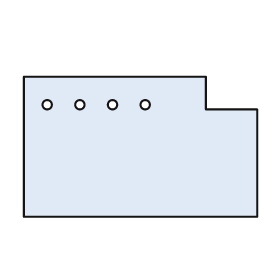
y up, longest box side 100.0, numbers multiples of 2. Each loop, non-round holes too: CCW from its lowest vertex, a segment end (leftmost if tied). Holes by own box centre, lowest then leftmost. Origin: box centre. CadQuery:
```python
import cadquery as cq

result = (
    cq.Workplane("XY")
    .moveTo(-50.0, -30.0)
    .lineTo(50.0, -30.0)
    .lineTo(50.0, 16.0)
    .lineTo(28.0, 16.0)
    .lineTo(28.0, 30.0)
    .lineTo(-50.0, 30.0)
    .close()
    .moveTo(-40.0, 18.0)
    .circle(2.0)
    .moveTo(-26.0, 18.0)
    .circle(2.0)
    .moveTo(-12.0, 18.0)
    .circle(2.0)
    .moveTo(2.0, 18.0)
    .circle(2.0)
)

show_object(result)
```